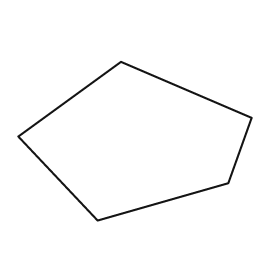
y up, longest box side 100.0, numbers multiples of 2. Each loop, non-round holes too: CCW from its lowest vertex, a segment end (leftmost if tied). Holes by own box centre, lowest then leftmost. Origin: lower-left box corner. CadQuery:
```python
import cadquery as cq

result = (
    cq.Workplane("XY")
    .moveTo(34.0, 0.0)
    .lineTo(90.0, 16.0)
    .lineTo(100.0, 44.0)
    .lineTo(44.0, 68.0)
    .lineTo(0.0, 36.0)
    .close()
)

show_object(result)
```